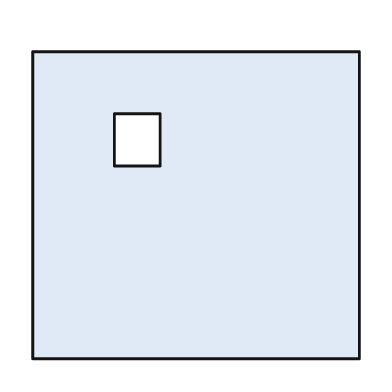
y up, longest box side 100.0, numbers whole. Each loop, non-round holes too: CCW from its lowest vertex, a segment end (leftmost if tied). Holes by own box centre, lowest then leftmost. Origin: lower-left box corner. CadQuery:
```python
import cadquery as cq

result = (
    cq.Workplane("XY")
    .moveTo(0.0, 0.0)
    .lineTo(100.0, 0.0)
    .lineTo(100.0, 94.0)
    .lineTo(0.0, 94.0)
    .close()
    .moveTo(25.0, 59.0)
    .lineTo(39.0, 59.0)
    .lineTo(39.0, 75.0)
    .lineTo(25.0, 75.0)
    .close()
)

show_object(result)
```